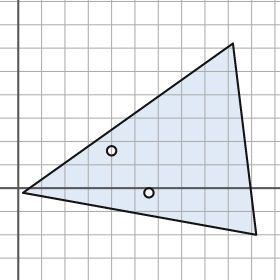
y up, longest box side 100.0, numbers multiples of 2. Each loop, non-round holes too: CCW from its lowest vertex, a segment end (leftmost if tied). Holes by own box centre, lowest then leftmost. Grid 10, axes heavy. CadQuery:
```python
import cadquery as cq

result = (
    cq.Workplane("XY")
    .moveTo(102.0, -20.0)
    .lineTo(92.0, 62.0)
    .lineTo(2.0, -2.0)
    .close()
    .moveTo(56.0, -2.0)
    .circle(2.0)
    .moveTo(40.0, 16.0)
    .circle(2.0)
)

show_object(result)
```